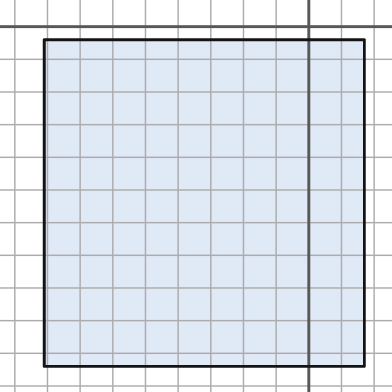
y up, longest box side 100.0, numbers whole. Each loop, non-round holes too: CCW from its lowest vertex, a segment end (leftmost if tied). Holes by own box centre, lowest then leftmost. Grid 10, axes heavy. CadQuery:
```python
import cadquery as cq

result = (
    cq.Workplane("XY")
    .moveTo(-81.0, -104.0)
    .lineTo(17.0, -104.0)
    .lineTo(17.0, -4.0)
    .lineTo(-81.0, -4.0)
    .close()
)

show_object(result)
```